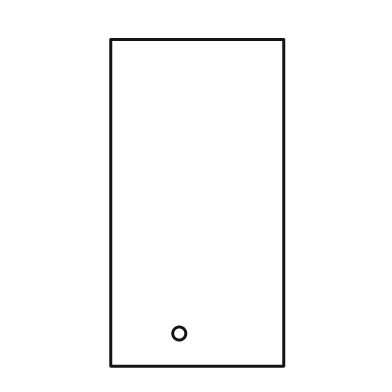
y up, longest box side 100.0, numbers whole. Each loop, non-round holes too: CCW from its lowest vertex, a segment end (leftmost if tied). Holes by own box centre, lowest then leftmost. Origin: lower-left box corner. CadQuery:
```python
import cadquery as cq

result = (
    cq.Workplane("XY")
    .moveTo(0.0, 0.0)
    .lineTo(53.0, 0.0)
    .lineTo(53.0, 100.0)
    .lineTo(0.0, 100.0)
    .close()
    .moveTo(21.0, 10.0)
    .circle(2.0)
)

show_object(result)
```